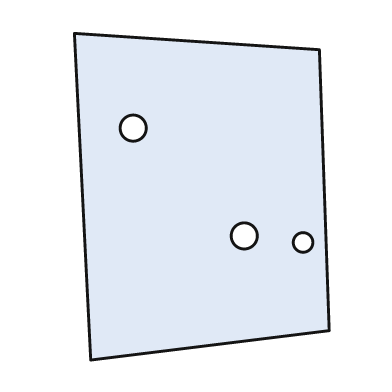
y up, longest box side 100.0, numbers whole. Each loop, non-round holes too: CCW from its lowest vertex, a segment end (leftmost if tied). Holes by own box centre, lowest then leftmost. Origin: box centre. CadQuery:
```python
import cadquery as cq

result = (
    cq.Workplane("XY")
    .moveTo(-34.0, -50.0)
    .lineTo(39.0, -41.0)
    .lineTo(36.0, 45.0)
    .lineTo(-39.0, 50.0)
    .close()
    .moveTo(31.0, -14.0)
    .circle(3.0)
    .moveTo(13.0, -12.0)
    .circle(4.0)
    .moveTo(-21.0, 21.0)
    .circle(4.0)
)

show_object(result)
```